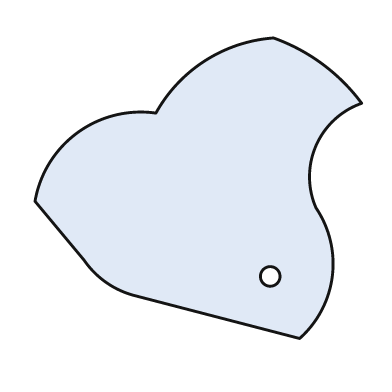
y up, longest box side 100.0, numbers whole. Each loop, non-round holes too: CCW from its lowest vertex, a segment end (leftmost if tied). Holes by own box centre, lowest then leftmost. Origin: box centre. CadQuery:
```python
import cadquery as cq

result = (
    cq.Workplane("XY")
    .moveTo(31.0, -46.0)
    .threePointArc((41.0, -27.0), (36.0, -6.0))
    .threePointArc((36.0, 13.0), (50.0, 26.0))
    .threePointArc((38.0, 38.0), (23.0, 46.0))
    .threePointArc((2.0, 39.0), (-13.0, 23.0))
    .threePointArc((-37.0, 17.0), (-50.0, -4.0))
    .lineTo(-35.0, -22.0)
    .threePointArc((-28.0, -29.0), (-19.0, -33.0))
    .close()
    .moveTo(22.0, -27.0)
    .circle(3.0)
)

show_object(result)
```